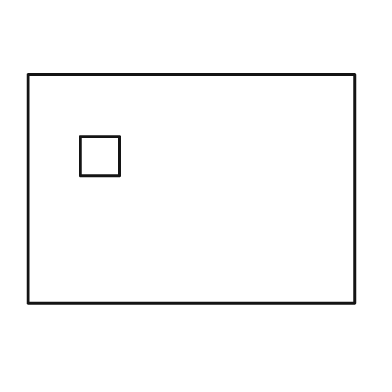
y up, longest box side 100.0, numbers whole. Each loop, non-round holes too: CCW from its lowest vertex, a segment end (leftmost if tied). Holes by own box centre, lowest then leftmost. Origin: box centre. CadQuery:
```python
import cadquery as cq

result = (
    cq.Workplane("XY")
    .moveTo(-50.0, -35.0)
    .lineTo(50.0, -35.0)
    .lineTo(50.0, 35.0)
    .lineTo(-50.0, 35.0)
    .close()
    .moveTo(-34.0, 4.0)
    .lineTo(-22.0, 4.0)
    .lineTo(-22.0, 16.0)
    .lineTo(-34.0, 16.0)
    .close()
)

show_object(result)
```